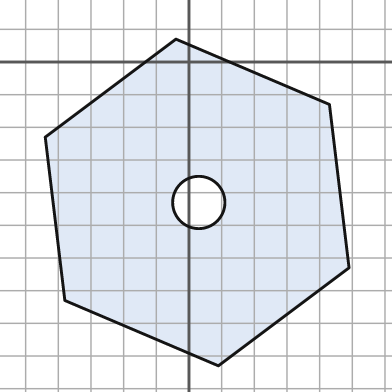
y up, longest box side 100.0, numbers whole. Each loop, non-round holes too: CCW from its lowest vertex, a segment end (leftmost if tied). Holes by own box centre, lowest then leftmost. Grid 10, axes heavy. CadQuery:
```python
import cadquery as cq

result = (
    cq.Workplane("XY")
    .moveTo(9.0, -93.0)
    .lineTo(49.0, -63.0)
    .lineTo(43.0, -13.0)
    .lineTo(-4.0, 7.0)
    .lineTo(-44.0, -23.0)
    .lineTo(-38.0, -73.0)
    .close()
    .moveTo(3.0, -43.0)
    .circle(8.0)
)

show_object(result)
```